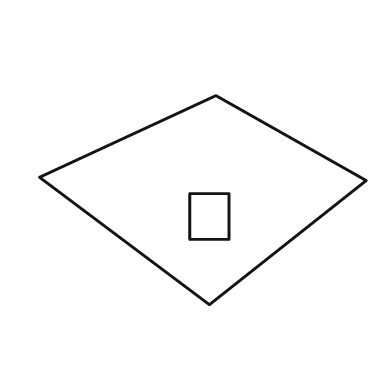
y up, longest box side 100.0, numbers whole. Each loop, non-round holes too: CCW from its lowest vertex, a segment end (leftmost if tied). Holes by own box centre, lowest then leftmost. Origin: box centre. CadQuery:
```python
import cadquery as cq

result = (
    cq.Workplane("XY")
    .moveTo(2.0, -32.0)
    .lineTo(50.0, 6.0)
    .lineTo(4.0, 32.0)
    .lineTo(-50.0, 7.0)
    .close()
    .moveTo(-4.0, -12.0)
    .lineTo(8.0, -12.0)
    .lineTo(8.0, 2.0)
    .lineTo(-4.0, 2.0)
    .close()
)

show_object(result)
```